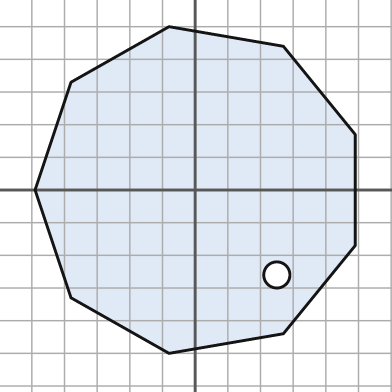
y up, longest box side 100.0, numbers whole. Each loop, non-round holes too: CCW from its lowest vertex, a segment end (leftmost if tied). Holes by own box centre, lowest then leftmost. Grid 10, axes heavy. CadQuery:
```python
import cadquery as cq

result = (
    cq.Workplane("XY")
    .moveTo(-8.0, -50.0)
    .lineTo(27.0, -44.0)
    .lineTo(49.0, -17.0)
    .lineTo(49.0, 17.0)
    .lineTo(27.0, 44.0)
    .lineTo(-8.0, 50.0)
    .lineTo(-38.0, 33.0)
    .lineTo(-49.0, 0.0)
    .lineTo(-38.0, -33.0)
    .close()
    .moveTo(25.0, -26.0)
    .circle(4.0)
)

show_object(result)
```